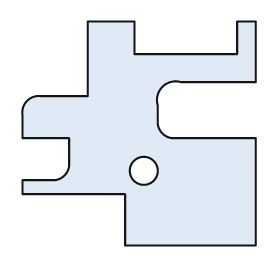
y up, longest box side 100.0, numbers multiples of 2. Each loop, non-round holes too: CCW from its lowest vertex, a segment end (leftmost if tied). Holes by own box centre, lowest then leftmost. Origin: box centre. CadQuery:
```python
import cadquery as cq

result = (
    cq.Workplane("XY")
    .moveTo(-6.0, -48.0)
    .lineTo(50.0, -48.0)
    .lineTo(50.0, -2.0)
    .lineTo(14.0, -2.0)
    .threePointArc((10.0, 0.0), (8.0, 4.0))
    .lineTo(8.0, 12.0)
    .threePointArc((10.0, 20.0), (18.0, 22.0))
    .lineTo(50.0, 22.0)
    .lineTo(50.0, 48.0)
    .lineTo(42.0, 48.0)
    .lineTo(42.0, 34.0)
    .lineTo(-2.0, 34.0)
    .lineTo(-2.0, 48.0)
    .lineTo(-22.0, 48.0)
    .lineTo(-22.0, 16.0)
    .lineTo(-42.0, 16.0)
    .threePointArc((-48.0, 14.0), (-50.0, 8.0))
    .lineTo(-50.0, -2.0)
    .lineTo(-30.0, -2.0)
    .lineTo(-30.0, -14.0)
    .threePointArc((-32.0, -18.0), (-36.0, -20.0))
    .lineTo(-50.0, -20.0)
    .lineTo(-50.0, -26.0)
    .lineTo(-6.0, -26.0)
    .close()
    .moveTo(2.0, -16.0)
    .circle(6.0)
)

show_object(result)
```